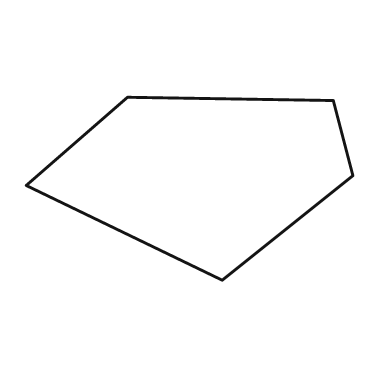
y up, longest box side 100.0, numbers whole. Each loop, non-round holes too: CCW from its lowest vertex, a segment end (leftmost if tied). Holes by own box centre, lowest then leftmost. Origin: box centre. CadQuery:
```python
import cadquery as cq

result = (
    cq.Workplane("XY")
    .moveTo(10.0, -28.0)
    .lineTo(50.0, 4.0)
    .lineTo(44.0, 27.0)
    .lineTo(-19.0, 28.0)
    .lineTo(-50.0, 1.0)
    .close()
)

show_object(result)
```